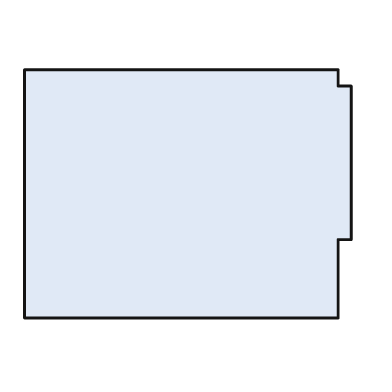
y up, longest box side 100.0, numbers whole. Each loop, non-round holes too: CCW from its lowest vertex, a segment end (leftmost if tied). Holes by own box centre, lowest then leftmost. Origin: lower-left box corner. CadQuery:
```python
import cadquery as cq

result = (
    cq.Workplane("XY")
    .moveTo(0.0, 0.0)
    .lineTo(96.0, 0.0)
    .lineTo(96.0, 24.0)
    .lineTo(100.0, 24.0)
    .lineTo(100.0, 71.0)
    .lineTo(96.0, 71.0)
    .lineTo(96.0, 76.0)
    .lineTo(0.0, 76.0)
    .close()
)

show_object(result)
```